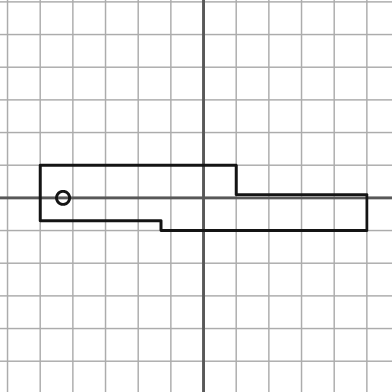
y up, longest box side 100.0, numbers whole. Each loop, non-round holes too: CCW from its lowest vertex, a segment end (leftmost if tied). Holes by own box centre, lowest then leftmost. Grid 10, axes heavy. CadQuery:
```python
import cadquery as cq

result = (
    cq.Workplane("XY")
    .moveTo(-13.0, -10.0)
    .lineTo(50.0, -10.0)
    .lineTo(50.0, 1.0)
    .lineTo(10.0, 1.0)
    .lineTo(10.0, 10.0)
    .lineTo(-50.0, 10.0)
    .lineTo(-50.0, -7.0)
    .lineTo(-13.0, -7.0)
    .close()
    .moveTo(-43.0, 0.0)
    .circle(2.0)
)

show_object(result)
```